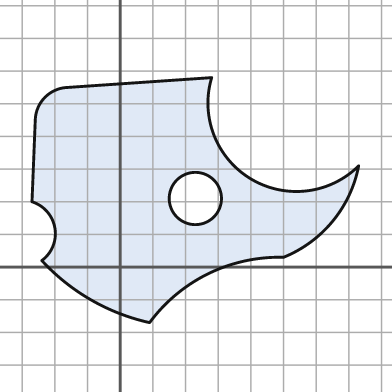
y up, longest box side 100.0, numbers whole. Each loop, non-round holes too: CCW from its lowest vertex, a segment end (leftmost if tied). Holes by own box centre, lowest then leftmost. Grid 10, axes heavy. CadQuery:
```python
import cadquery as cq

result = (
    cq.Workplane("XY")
    .moveTo(9.0, -17.0)
    .threePointArc((27.0, -2.0), (50.0, 3.0))
    .threePointArc((65.0, 14.0), (73.0, 31.0))
    .threePointArc((40.0, 27.0), (28.0, 58.0))
    .lineTo(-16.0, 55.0)
    .threePointArc((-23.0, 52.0), (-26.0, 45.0))
    .lineTo(-27.0, 20.0)
    .threePointArc((-20.0, 12.0), (-24.0, 2.0))
    .threePointArc((-9.0, -10.0), (9.0, -17.0))
    .close()
    .moveTo(23.0, 21.0)
    .circle(8.0)
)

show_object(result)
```